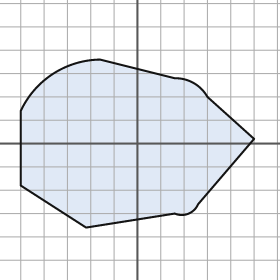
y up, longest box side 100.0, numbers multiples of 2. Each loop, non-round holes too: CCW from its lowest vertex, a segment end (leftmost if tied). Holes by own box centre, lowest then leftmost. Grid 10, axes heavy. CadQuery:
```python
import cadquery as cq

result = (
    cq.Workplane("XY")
    .moveTo(-22.0, -36.0)
    .lineTo(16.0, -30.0)
    .threePointArc((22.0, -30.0), (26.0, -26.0))
    .lineTo(50.0, 2.0)
    .lineTo(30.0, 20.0)
    .threePointArc((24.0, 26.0), (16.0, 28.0))
    .lineTo(-16.0, 36.0)
    .threePointArc((-36.0, 30.0), (-50.0, 14.0))
    .lineTo(-50.0, -18.0)
    .close()
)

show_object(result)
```